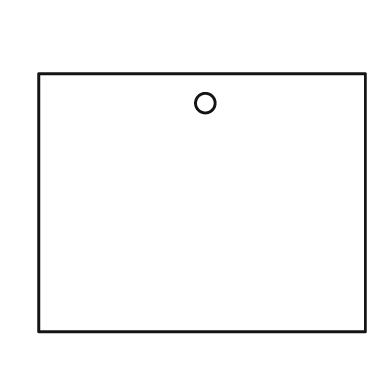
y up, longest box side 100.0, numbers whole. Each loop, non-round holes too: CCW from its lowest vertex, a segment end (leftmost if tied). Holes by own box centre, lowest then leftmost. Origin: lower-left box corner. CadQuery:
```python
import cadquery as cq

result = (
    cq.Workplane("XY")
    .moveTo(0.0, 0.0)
    .lineTo(100.0, 0.0)
    .lineTo(100.0, 79.0)
    .lineTo(0.0, 79.0)
    .close()
    .moveTo(51.0, 70.0)
    .circle(3.0)
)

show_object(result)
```